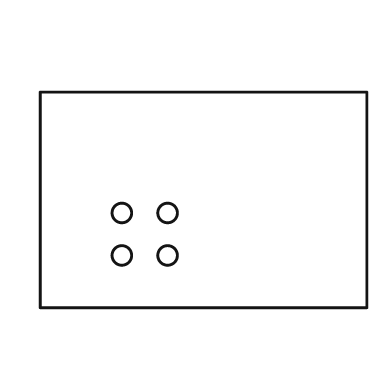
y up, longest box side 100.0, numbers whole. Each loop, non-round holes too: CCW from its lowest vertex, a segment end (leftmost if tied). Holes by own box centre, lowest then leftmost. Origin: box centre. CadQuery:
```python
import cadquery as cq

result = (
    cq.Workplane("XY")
    .moveTo(-50.0, -33.0)
    .lineTo(50.0, -33.0)
    .lineTo(50.0, 33.0)
    .lineTo(-50.0, 33.0)
    .close()
    .moveTo(-25.0, -17.0)
    .circle(3.0)
    .moveTo(-11.0, -17.0)
    .circle(3.0)
    .moveTo(-25.0, -4.0)
    .circle(3.0)
    .moveTo(-11.0, -4.0)
    .circle(3.0)
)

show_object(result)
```